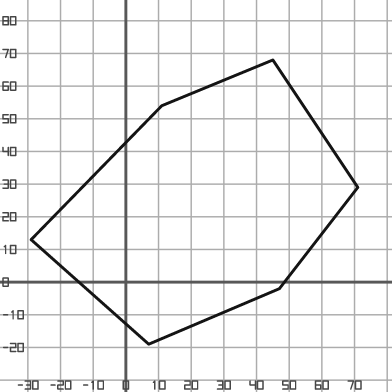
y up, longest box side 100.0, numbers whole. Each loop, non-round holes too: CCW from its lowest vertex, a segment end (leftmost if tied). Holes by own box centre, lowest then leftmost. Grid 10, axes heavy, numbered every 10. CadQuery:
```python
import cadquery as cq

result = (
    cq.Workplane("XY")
    .moveTo(7.0, -19.0)
    .lineTo(47.0, -2.0)
    .lineTo(71.0, 29.0)
    .lineTo(45.0, 68.0)
    .lineTo(11.0, 54.0)
    .lineTo(-29.0, 13.0)
    .close()
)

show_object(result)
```